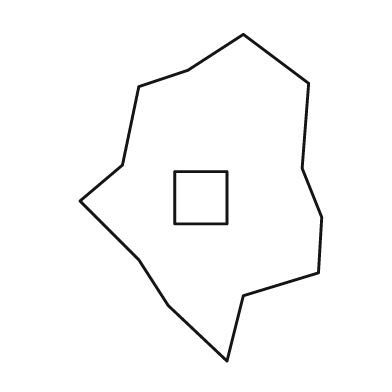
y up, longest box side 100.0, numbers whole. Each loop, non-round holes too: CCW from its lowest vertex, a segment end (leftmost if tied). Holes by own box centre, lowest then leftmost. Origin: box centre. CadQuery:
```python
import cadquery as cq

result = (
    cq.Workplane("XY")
    .moveTo(8.0, -50.0)
    .lineTo(13.0, -30.0)
    .lineTo(36.0, -23.0)
    .lineTo(37.0, -6.0)
    .lineTo(31.0, 9.0)
    .lineTo(33.0, 35.0)
    .lineTo(13.0, 50.0)
    .lineTo(-4.0, 39.0)
    .lineTo(-19.0, 34.0)
    .lineTo(-24.0, 10.0)
    .lineTo(-37.0, -1.0)
    .lineTo(-19.0, -19.0)
    .lineTo(-10.0, -33.0)
    .close()
    .moveTo(-8.0, -8.0)
    .lineTo(8.0, -8.0)
    .lineTo(8.0, 8.0)
    .lineTo(-8.0, 8.0)
    .close()
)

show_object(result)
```